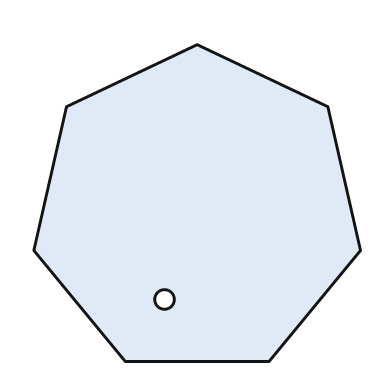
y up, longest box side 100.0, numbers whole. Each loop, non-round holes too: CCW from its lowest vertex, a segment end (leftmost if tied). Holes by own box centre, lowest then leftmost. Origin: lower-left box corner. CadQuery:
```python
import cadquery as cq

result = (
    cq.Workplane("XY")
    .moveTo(28.0, 0.0)
    .lineTo(72.0, 0.0)
    .lineTo(100.0, 34.0)
    .lineTo(90.0, 78.0)
    .lineTo(50.0, 97.0)
    .lineTo(10.0, 78.0)
    .lineTo(0.0, 34.0)
    .close()
    .moveTo(40.0, 19.0)
    .circle(3.0)
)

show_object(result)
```